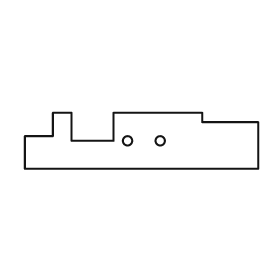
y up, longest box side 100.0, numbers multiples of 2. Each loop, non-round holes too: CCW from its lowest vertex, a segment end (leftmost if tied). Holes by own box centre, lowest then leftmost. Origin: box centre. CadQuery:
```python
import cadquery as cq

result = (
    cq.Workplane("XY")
    .moveTo(-50.0, -12.0)
    .lineTo(50.0, -12.0)
    .lineTo(50.0, 8.0)
    .lineTo(26.0, 8.0)
    .lineTo(26.0, 12.0)
    .lineTo(-12.0, 12.0)
    .lineTo(-12.0, 0.0)
    .lineTo(-30.0, 0.0)
    .lineTo(-30.0, 12.0)
    .lineTo(-38.0, 12.0)
    .lineTo(-38.0, 2.0)
    .lineTo(-50.0, 2.0)
    .close()
    .moveTo(-6.0, 0.0)
    .circle(2.0)
    .moveTo(8.0, 0.0)
    .circle(2.0)
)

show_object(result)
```